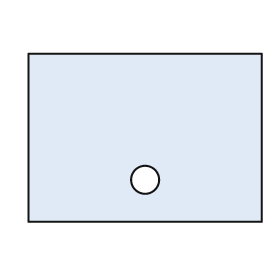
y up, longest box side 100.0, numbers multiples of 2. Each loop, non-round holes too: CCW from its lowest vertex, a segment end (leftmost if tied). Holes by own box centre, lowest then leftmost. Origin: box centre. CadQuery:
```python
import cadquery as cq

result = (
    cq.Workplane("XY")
    .moveTo(-50.0, -36.0)
    .lineTo(50.0, -36.0)
    .lineTo(50.0, 36.0)
    .lineTo(-50.0, 36.0)
    .close()
    .moveTo(0.0, -18.0)
    .circle(6.0)
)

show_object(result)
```